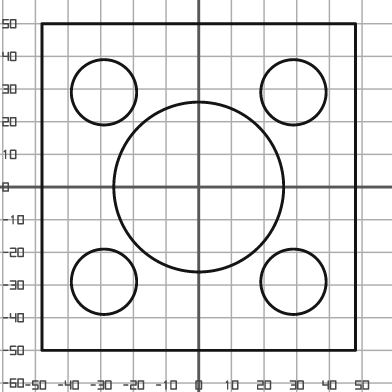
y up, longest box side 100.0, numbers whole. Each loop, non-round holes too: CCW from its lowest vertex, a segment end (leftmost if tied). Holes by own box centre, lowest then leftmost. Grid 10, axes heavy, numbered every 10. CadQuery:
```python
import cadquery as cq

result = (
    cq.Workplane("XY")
    .moveTo(-48.0, -50.0)
    .lineTo(48.0, -50.0)
    .lineTo(48.0, 50.0)
    .lineTo(-48.0, 50.0)
    .close()
    .moveTo(-29.0, -29.0)
    .circle(10.0)
    .moveTo(29.0, -29.0)
    .circle(10.0)
    .moveTo(0.0, 0.0)
    .circle(26.0)
    .moveTo(-29.0, 29.0)
    .circle(10.0)
    .moveTo(29.0, 29.0)
    .circle(10.0)
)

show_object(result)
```